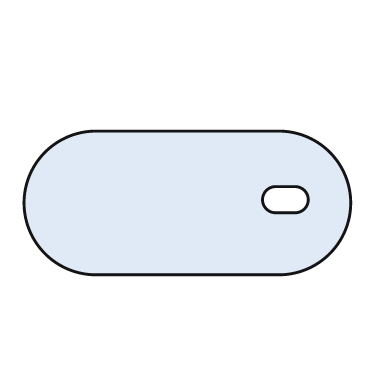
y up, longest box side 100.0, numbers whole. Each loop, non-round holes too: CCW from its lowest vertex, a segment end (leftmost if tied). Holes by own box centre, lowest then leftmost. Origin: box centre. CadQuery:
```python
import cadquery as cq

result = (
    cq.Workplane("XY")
    .moveTo(-28.0, -22.0)
    .lineTo(28.0, -22.0)
    .threePointArc((50.0, 0.0), (28.0, 22.0))
    .lineTo(-28.0, 22.0)
    .threePointArc((-50.0, 0.0), (-28.0, -22.0))
    .close()
    .moveTo(27.0, -3.0)
    .lineTo(33.0, -3.0)
    .threePointArc((37.0, 1.0), (33.0, 5.0))
    .lineTo(27.0, 5.0)
    .threePointArc((23.0, 1.0), (27.0, -3.0))
    .close()
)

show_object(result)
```